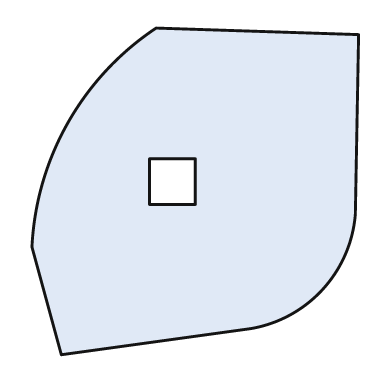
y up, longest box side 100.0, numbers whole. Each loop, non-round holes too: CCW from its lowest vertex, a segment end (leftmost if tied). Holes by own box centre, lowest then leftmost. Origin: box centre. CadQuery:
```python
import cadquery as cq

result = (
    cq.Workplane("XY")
    .moveTo(-41.0, -50.0)
    .lineTo(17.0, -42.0)
    .threePointArc((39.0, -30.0), (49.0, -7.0))
    .lineTo(50.0, 48.0)
    .lineTo(-12.0, 50.0)
    .threePointArc((-39.0, 21.0), (-50.0, -17.0))
    .close()
    .moveTo(-14.0, -4.0)
    .lineTo(0.0, -4.0)
    .lineTo(0.0, 10.0)
    .lineTo(-14.0, 10.0)
    .close()
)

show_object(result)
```